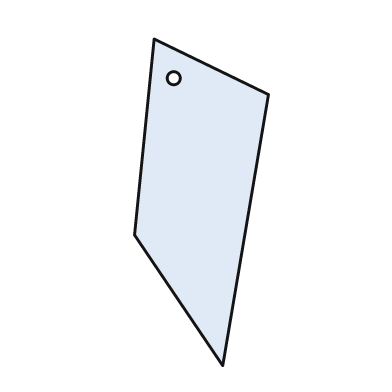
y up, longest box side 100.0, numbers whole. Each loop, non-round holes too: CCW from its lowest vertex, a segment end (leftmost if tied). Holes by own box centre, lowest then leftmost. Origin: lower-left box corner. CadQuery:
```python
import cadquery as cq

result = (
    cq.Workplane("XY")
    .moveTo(27.0, 0.0)
    .lineTo(41.0, 83.0)
    .lineTo(6.0, 100.0)
    .lineTo(0.0, 40.0)
    .close()
    .moveTo(12.0, 88.0)
    .circle(2.0)
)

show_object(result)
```